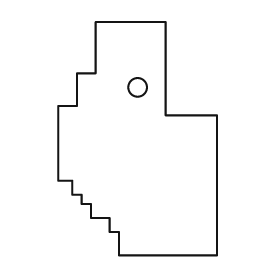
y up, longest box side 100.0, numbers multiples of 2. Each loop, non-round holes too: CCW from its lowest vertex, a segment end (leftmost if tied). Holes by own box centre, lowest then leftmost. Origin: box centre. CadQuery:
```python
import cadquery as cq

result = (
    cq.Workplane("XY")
    .moveTo(-8.0, -50.0)
    .lineTo(34.0, -50.0)
    .lineTo(34.0, 10.0)
    .lineTo(12.0, 10.0)
    .lineTo(12.0, 50.0)
    .lineTo(-18.0, 50.0)
    .lineTo(-18.0, 28.0)
    .lineTo(-26.0, 28.0)
    .lineTo(-26.0, 14.0)
    .lineTo(-34.0, 14.0)
    .lineTo(-34.0, -18.0)
    .lineTo(-28.0, -18.0)
    .lineTo(-28.0, -24.0)
    .lineTo(-24.0, -24.0)
    .lineTo(-24.0, -28.0)
    .lineTo(-20.0, -28.0)
    .lineTo(-20.0, -34.0)
    .lineTo(-12.0, -34.0)
    .lineTo(-12.0, -40.0)
    .lineTo(-8.0, -40.0)
    .close()
    .moveTo(0.0, 22.0)
    .circle(4.0)
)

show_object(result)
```